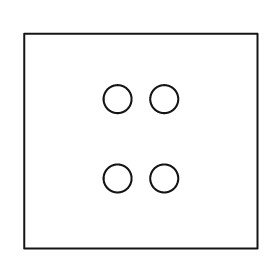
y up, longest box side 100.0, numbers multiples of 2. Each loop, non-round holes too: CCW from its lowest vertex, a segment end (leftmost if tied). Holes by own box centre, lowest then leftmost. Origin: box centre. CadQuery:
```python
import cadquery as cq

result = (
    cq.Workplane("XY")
    .moveTo(-50.0, -46.0)
    .lineTo(50.0, -46.0)
    .lineTo(50.0, 46.0)
    .lineTo(-50.0, 46.0)
    .close()
    .moveTo(-10.0, -16.0)
    .circle(6.0)
    .moveTo(10.0, -16.0)
    .circle(6.0)
    .moveTo(-10.0, 18.0)
    .circle(6.0)
    .moveTo(10.0, 18.0)
    .circle(6.0)
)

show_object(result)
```